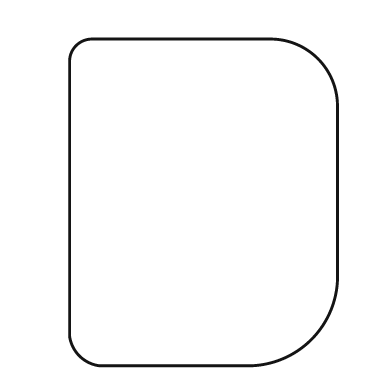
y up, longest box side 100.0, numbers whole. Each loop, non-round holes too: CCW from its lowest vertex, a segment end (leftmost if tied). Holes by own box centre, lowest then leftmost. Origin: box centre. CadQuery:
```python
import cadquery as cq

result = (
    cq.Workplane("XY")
    .moveTo(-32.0, -50.0)
    .lineTo(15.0, -50.0)
    .threePointArc((33.0, -42.0), (41.0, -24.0))
    .lineTo(41.0, 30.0)
    .threePointArc((35.0, 44.0), (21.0, 50.0))
    .lineTo(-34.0, 50.0)
    .threePointArc((-39.0, 48.0), (-41.0, 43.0))
    .lineTo(-41.0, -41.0)
    .threePointArc((-38.0, -47.0), (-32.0, -50.0))
    .close()
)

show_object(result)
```